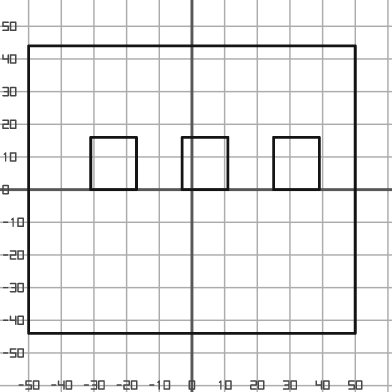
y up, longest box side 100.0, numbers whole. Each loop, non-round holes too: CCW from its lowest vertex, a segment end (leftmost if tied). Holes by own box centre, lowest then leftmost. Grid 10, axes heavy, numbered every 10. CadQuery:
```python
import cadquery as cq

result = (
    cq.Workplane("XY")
    .moveTo(-50.0, -44.0)
    .lineTo(50.0, -44.0)
    .lineTo(50.0, 44.0)
    .lineTo(-50.0, 44.0)
    .close()
    .moveTo(-31.0, 0.0)
    .lineTo(-17.0, 0.0)
    .lineTo(-17.0, 16.0)
    .lineTo(-31.0, 16.0)
    .close()
    .moveTo(-3.0, 0.0)
    .lineTo(11.0, 0.0)
    .lineTo(11.0, 16.0)
    .lineTo(-3.0, 16.0)
    .close()
    .moveTo(25.0, 0.0)
    .lineTo(39.0, 0.0)
    .lineTo(39.0, 16.0)
    .lineTo(25.0, 16.0)
    .close()
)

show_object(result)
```